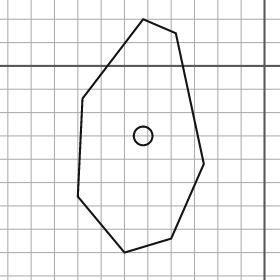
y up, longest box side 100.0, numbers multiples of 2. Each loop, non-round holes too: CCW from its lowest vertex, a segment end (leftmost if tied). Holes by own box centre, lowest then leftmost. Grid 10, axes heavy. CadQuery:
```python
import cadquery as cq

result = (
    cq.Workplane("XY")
    .moveTo(-60.0, -80.0)
    .lineTo(-40.0, -74.0)
    .lineTo(-26.0, -42.0)
    .lineTo(-38.0, 14.0)
    .lineTo(-52.0, 20.0)
    .lineTo(-78.0, -14.0)
    .lineTo(-80.0, -56.0)
    .close()
    .moveTo(-52.0, -30.0)
    .circle(4.0)
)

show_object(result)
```